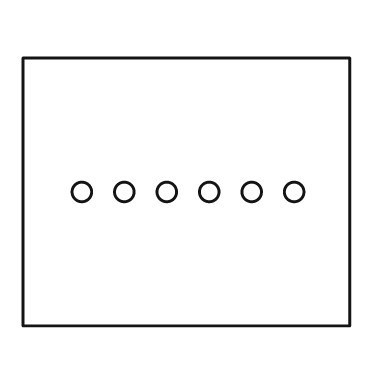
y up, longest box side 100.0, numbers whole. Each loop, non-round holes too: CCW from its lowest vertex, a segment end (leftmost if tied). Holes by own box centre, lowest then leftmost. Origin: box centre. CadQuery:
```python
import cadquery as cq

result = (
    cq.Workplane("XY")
    .moveTo(-50.0, -41.0)
    .lineTo(50.0, -41.0)
    .lineTo(50.0, 41.0)
    .lineTo(-50.0, 41.0)
    .close()
    .moveTo(-32.0, 0.0)
    .circle(3.0)
    .moveTo(-19.0, 0.0)
    .circle(3.0)
    .moveTo(-6.0, 0.0)
    .circle(3.0)
    .moveTo(7.0, 0.0)
    .circle(3.0)
    .moveTo(20.0, 0.0)
    .circle(3.0)
    .moveTo(33.0, 0.0)
    .circle(3.0)
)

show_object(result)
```